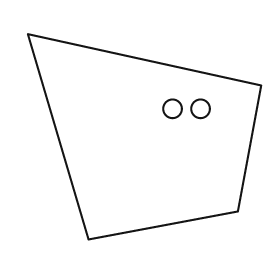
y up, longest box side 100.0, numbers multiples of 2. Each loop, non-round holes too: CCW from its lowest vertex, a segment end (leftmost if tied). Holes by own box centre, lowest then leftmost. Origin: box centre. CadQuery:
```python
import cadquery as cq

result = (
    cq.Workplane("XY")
    .moveTo(-24.0, -44.0)
    .lineTo(40.0, -32.0)
    .lineTo(50.0, 22.0)
    .lineTo(-50.0, 44.0)
    .close()
    .moveTo(12.0, 12.0)
    .circle(4.0)
    .moveTo(24.0, 12.0)
    .circle(4.0)
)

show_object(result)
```